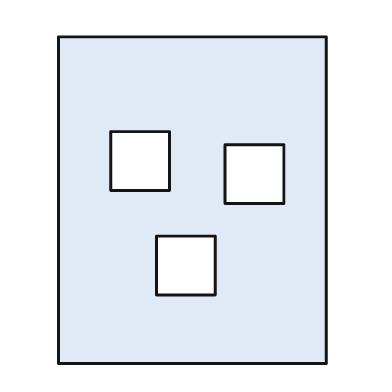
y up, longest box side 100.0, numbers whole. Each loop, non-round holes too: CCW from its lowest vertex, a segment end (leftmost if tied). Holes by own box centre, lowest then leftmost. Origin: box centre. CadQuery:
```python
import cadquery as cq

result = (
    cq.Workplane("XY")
    .moveTo(-41.0, -50.0)
    .lineTo(41.0, -50.0)
    .lineTo(41.0, 50.0)
    .lineTo(-41.0, 50.0)
    .close()
    .moveTo(-11.0, -29.0)
    .lineTo(7.0, -29.0)
    .lineTo(7.0, -11.0)
    .lineTo(-11.0, -11.0)
    .close()
    .moveTo(10.0, -1.0)
    .lineTo(28.0, -1.0)
    .lineTo(28.0, 17.0)
    .lineTo(10.0, 17.0)
    .close()
    .moveTo(-25.0, 3.0)
    .lineTo(-7.0, 3.0)
    .lineTo(-7.0, 21.0)
    .lineTo(-25.0, 21.0)
    .close()
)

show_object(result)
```